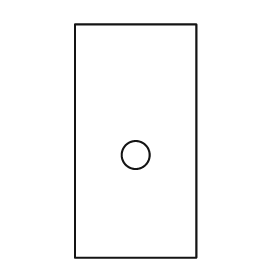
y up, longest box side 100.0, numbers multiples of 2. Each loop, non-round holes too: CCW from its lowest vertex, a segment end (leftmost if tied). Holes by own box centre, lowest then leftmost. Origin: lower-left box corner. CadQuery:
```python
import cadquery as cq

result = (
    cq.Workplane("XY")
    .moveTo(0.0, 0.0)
    .lineTo(52.0, 0.0)
    .lineTo(52.0, 100.0)
    .lineTo(0.0, 100.0)
    .close()
    .moveTo(26.0, 44.0)
    .circle(6.0)
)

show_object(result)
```